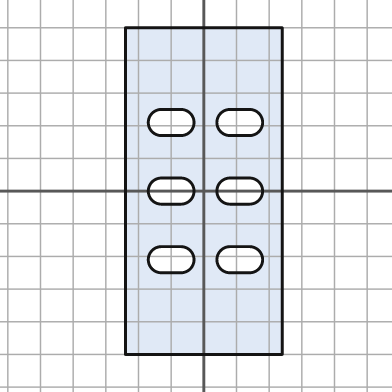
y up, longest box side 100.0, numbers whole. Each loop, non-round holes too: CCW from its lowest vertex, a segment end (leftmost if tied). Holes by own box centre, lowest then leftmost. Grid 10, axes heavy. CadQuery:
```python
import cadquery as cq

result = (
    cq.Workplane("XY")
    .moveTo(-24.0, -50.0)
    .lineTo(24.0, -50.0)
    .lineTo(24.0, 50.0)
    .lineTo(-24.0, 50.0)
    .close()
    .moveTo(-13.0, -25.0)
    .lineTo(-7.0, -25.0)
    .threePointArc((-3.0, -21.0), (-7.0, -17.0))
    .lineTo(-13.0, -17.0)
    .threePointArc((-17.0, -21.0), (-13.0, -25.0))
    .close()
    .moveTo(8.0, -25.0)
    .lineTo(14.0, -25.0)
    .threePointArc((18.0, -21.0), (14.0, -17.0))
    .lineTo(8.0, -17.0)
    .threePointArc((4.0, -21.0), (8.0, -25.0))
    .close()
    .moveTo(-13.0, -4.0)
    .lineTo(-7.0, -4.0)
    .threePointArc((-3.0, 0.0), (-7.0, 4.0))
    .lineTo(-13.0, 4.0)
    .threePointArc((-17.0, 0.0), (-13.0, -4.0))
    .close()
    .moveTo(8.0, -4.0)
    .lineTo(14.0, -4.0)
    .threePointArc((18.0, 0.0), (14.0, 4.0))
    .lineTo(8.0, 4.0)
    .threePointArc((4.0, 0.0), (8.0, -4.0))
    .close()
    .moveTo(-13.0, 17.0)
    .lineTo(-7.0, 17.0)
    .threePointArc((-3.0, 21.0), (-7.0, 25.0))
    .lineTo(-13.0, 25.0)
    .threePointArc((-17.0, 21.0), (-13.0, 17.0))
    .close()
    .moveTo(8.0, 17.0)
    .lineTo(14.0, 17.0)
    .threePointArc((18.0, 21.0), (14.0, 25.0))
    .lineTo(8.0, 25.0)
    .threePointArc((4.0, 21.0), (8.0, 17.0))
    .close()
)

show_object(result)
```